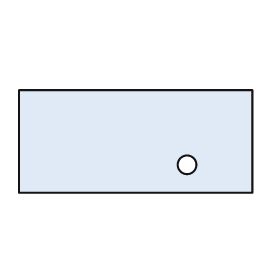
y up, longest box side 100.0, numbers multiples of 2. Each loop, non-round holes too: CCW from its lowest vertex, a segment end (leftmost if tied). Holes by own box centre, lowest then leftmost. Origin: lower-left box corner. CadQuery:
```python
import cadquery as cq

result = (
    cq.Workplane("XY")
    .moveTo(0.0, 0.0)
    .lineTo(100.0, 0.0)
    .lineTo(100.0, 44.0)
    .lineTo(0.0, 44.0)
    .close()
    .moveTo(72.0, 12.0)
    .circle(4.0)
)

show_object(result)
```